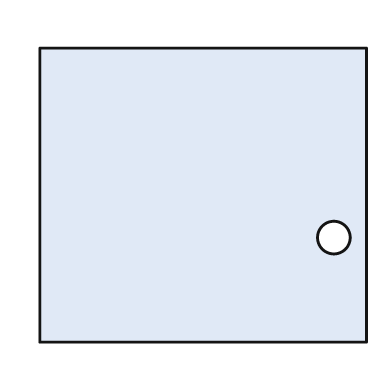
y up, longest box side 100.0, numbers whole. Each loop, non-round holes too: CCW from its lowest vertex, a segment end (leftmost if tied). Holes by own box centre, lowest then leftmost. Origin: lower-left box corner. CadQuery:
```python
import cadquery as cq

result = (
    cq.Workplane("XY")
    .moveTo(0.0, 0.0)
    .lineTo(100.0, 0.0)
    .lineTo(100.0, 90.0)
    .lineTo(0.0, 90.0)
    .close()
    .moveTo(90.0, 32.0)
    .circle(5.0)
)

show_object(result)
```